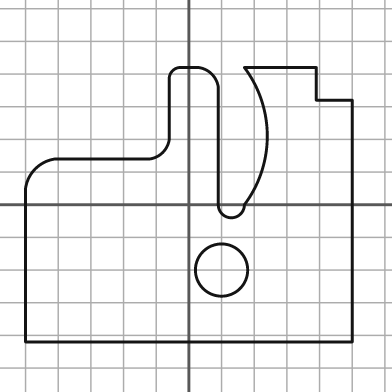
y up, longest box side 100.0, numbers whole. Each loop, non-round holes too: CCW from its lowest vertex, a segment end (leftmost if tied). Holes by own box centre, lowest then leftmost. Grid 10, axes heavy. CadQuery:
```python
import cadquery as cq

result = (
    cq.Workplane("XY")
    .moveTo(-50.0, -42.0)
    .lineTo(50.0, -42.0)
    .lineTo(50.0, 32.0)
    .lineTo(39.0, 32.0)
    .lineTo(39.0, 42.0)
    .lineTo(17.0, 42.0)
    .threePointArc((24.0, 21.0), (17.0, 0.0))
    .threePointArc((13.0, -4.0), (9.0, 0.0))
    .lineTo(9.0, 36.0)
    .threePointArc((7.0, 40.0), (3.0, 42.0))
    .lineTo(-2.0, 42.0)
    .threePointArc((-5.0, 41.0), (-6.0, 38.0))
    .lineTo(-6.0, 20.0)
    .threePointArc((-8.0, 16.0), (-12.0, 14.0))
    .lineTo(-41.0, 14.0)
    .threePointArc((-47.0, 11.0), (-50.0, 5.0))
    .close()
    .moveTo(10.0, -20.0)
    .circle(8.0)
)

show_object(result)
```